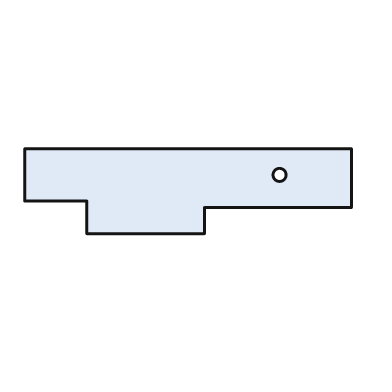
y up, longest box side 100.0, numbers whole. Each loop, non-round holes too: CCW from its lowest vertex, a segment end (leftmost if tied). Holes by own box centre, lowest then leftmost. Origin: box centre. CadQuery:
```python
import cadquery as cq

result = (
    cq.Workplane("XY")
    .moveTo(-31.0, -13.0)
    .lineTo(5.0, -13.0)
    .lineTo(5.0, -5.0)
    .lineTo(50.0, -5.0)
    .lineTo(50.0, 13.0)
    .lineTo(-50.0, 13.0)
    .lineTo(-50.0, -3.0)
    .lineTo(-31.0, -3.0)
    .close()
    .moveTo(28.0, 5.0)
    .circle(2.0)
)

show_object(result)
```